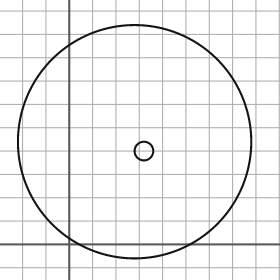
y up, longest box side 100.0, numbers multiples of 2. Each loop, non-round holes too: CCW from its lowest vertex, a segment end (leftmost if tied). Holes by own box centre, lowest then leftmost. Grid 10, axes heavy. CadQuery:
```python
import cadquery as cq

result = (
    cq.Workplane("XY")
    .moveTo(28.0, 44.0)
    .circle(50.0)
    .moveTo(32.0, 40.0)
    .circle(4.0)
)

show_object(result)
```